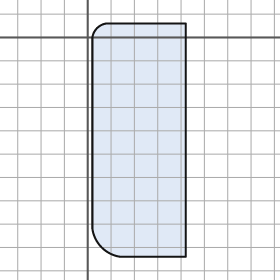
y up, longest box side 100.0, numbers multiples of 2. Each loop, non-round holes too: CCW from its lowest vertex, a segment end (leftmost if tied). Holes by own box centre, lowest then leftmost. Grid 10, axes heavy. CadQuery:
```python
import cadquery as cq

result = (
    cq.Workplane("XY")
    .moveTo(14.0, -94.0)
    .lineTo(42.0, -94.0)
    .lineTo(42.0, 6.0)
    .lineTo(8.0, 6.0)
    .threePointArc((4.0, 4.0), (2.0, 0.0))
    .lineTo(2.0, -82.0)
    .threePointArc((6.0, -90.0), (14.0, -94.0))
    .close()
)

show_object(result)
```